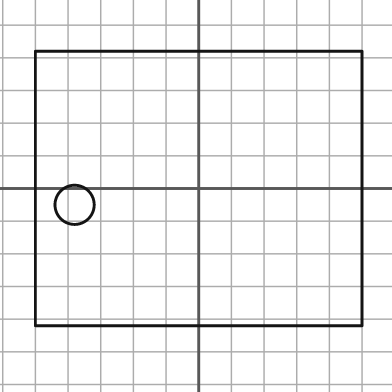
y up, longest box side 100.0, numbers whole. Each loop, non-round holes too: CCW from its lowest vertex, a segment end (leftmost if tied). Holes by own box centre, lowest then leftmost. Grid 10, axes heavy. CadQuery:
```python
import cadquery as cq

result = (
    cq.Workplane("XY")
    .moveTo(-50.0, -42.0)
    .lineTo(50.0, -42.0)
    .lineTo(50.0, 42.0)
    .lineTo(-50.0, 42.0)
    .close()
    .moveTo(-38.0, -5.0)
    .circle(6.0)
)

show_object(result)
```